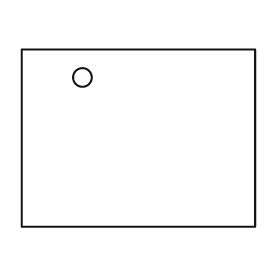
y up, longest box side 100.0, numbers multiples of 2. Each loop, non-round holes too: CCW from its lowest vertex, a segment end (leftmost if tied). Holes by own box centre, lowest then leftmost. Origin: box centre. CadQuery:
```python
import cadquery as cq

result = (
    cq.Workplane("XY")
    .moveTo(-50.0, -38.0)
    .lineTo(50.0, -38.0)
    .lineTo(50.0, 38.0)
    .lineTo(-50.0, 38.0)
    .close()
    .moveTo(-24.0, 26.0)
    .circle(4.0)
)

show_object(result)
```